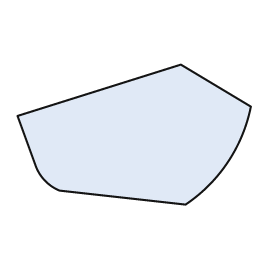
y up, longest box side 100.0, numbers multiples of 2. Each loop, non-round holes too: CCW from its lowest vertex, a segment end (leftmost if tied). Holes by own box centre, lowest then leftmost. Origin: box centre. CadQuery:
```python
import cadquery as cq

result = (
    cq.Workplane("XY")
    .moveTo(22.0, -30.0)
    .threePointArc((40.0, -12.0), (50.0, 12.0))
    .lineTo(20.0, 30.0)
    .lineTo(-50.0, 8.0)
    .lineTo(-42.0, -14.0)
    .threePointArc((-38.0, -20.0), (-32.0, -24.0))
    .close()
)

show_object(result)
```